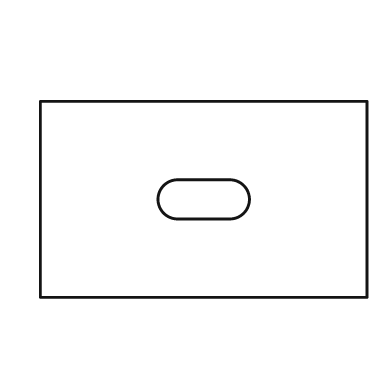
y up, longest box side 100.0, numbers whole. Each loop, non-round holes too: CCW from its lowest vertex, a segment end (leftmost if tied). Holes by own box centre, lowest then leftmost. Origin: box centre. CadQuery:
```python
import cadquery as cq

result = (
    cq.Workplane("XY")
    .moveTo(-50.0, -30.0)
    .lineTo(50.0, -30.0)
    .lineTo(50.0, 30.0)
    .lineTo(-50.0, 30.0)
    .close()
    .moveTo(-8.0, -6.0)
    .lineTo(8.0, -6.0)
    .threePointArc((14.0, 0.0), (8.0, 6.0))
    .lineTo(-8.0, 6.0)
    .threePointArc((-14.0, 0.0), (-8.0, -6.0))
    .close()
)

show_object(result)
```